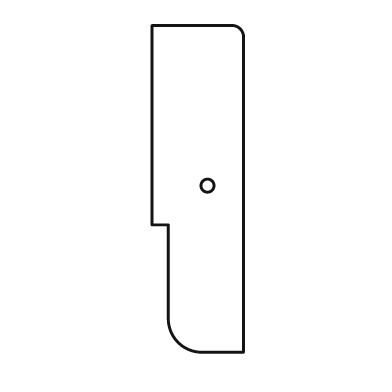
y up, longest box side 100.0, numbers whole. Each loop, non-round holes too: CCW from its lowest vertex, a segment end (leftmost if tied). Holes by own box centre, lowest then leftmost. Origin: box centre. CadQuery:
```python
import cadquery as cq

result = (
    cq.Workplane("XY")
    .moveTo(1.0, -50.0)
    .lineTo(14.0, -50.0)
    .lineTo(14.0, 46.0)
    .threePointArc((13.0, 49.0), (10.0, 50.0))
    .lineTo(-14.0, 50.0)
    .lineTo(-14.0, -11.0)
    .lineTo(-9.0, -11.0)
    .lineTo(-9.0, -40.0)
    .threePointArc((-6.0, -47.0), (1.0, -50.0))
    .close()
    .moveTo(3.0, 1.0)
    .circle(2.0)
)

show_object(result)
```